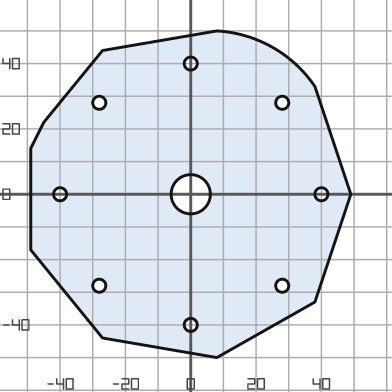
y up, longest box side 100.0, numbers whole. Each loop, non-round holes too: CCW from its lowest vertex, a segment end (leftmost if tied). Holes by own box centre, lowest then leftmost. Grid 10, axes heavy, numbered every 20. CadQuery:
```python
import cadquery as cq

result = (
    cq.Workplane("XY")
    .moveTo(8.0, -50.0)
    .lineTo(38.0, -33.0)
    .lineTo(49.0, 0.0)
    .lineTo(38.0, 33.0)
    .threePointArc((25.0, 45.0), (8.0, 50.0))
    .lineTo(-27.0, 44.0)
    .lineTo(-45.0, 22.0)
    .lineTo(-49.0, 14.0)
    .lineTo(-49.0, -17.0)
    .lineTo(-27.0, -44.0)
    .close()
    .moveTo(0.0, -40.0)
    .circle(2.0)
    .moveTo(-28.0, -28.0)
    .circle(2.0)
    .moveTo(28.0, -28.0)
    .circle(2.0)
    .moveTo(-40.0, 0.0)
    .circle(2.0)
    .moveTo(0.0, 0.0)
    .circle(6.0)
    .moveTo(40.0, 0.0)
    .circle(2.0)
    .moveTo(-28.0, 28.0)
    .circle(2.0)
    .moveTo(28.0, 28.0)
    .circle(2.0)
    .moveTo(0.0, 40.0)
    .circle(2.0)
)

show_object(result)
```